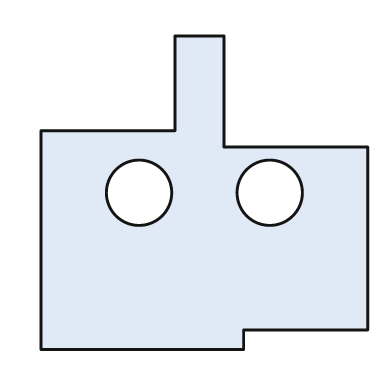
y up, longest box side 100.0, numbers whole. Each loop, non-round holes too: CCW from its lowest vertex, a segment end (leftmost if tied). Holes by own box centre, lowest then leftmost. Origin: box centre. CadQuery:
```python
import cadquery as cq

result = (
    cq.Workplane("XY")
    .moveTo(-50.0, -48.0)
    .lineTo(12.0, -48.0)
    .lineTo(12.0, -42.0)
    .lineTo(50.0, -42.0)
    .lineTo(50.0, 14.0)
    .lineTo(6.0, 14.0)
    .lineTo(6.0, 48.0)
    .lineTo(-9.0, 48.0)
    .lineTo(-9.0, 19.0)
    .lineTo(-50.0, 19.0)
    .close()
    .moveTo(-20.0, 0.0)
    .circle(10.0)
    .moveTo(20.0, 0.0)
    .circle(10.0)
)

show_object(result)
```